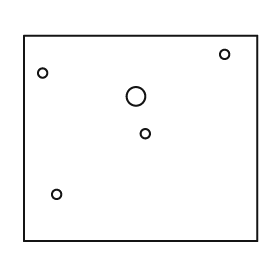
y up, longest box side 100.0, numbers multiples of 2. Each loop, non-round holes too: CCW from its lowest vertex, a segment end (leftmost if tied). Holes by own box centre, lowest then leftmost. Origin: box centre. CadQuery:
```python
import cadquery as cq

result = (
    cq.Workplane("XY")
    .moveTo(-50.0, -44.0)
    .lineTo(50.0, -44.0)
    .lineTo(50.0, 44.0)
    .lineTo(-50.0, 44.0)
    .close()
    .moveTo(-36.0, -24.0)
    .circle(2.0)
    .moveTo(2.0, 2.0)
    .circle(2.0)
    .moveTo(-2.0, 18.0)
    .circle(4.0)
    .moveTo(-42.0, 28.0)
    .circle(2.0)
    .moveTo(36.0, 36.0)
    .circle(2.0)
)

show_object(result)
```